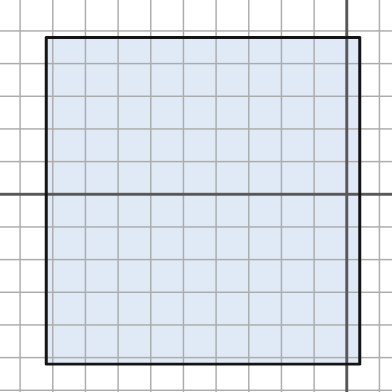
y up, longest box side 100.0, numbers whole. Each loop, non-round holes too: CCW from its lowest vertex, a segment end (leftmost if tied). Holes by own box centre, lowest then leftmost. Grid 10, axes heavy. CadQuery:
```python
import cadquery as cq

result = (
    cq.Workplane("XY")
    .moveTo(-92.0, -52.0)
    .lineTo(4.0, -52.0)
    .lineTo(4.0, 48.0)
    .lineTo(-92.0, 48.0)
    .close()
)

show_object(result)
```